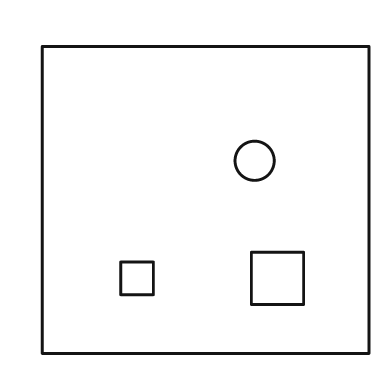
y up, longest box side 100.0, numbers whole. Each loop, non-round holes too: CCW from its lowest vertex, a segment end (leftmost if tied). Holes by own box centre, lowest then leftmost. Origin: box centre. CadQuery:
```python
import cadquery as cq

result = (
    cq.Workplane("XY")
    .moveTo(-50.0, -47.0)
    .lineTo(50.0, -47.0)
    .lineTo(50.0, 47.0)
    .lineTo(-50.0, 47.0)
    .close()
    .moveTo(-26.0, -29.0)
    .lineTo(-16.0, -29.0)
    .lineTo(-16.0, -19.0)
    .lineTo(-26.0, -19.0)
    .close()
    .moveTo(14.0, -32.0)
    .lineTo(30.0, -32.0)
    .lineTo(30.0, -16.0)
    .lineTo(14.0, -16.0)
    .close()
    .moveTo(15.0, 12.0)
    .circle(6.0)
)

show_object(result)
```